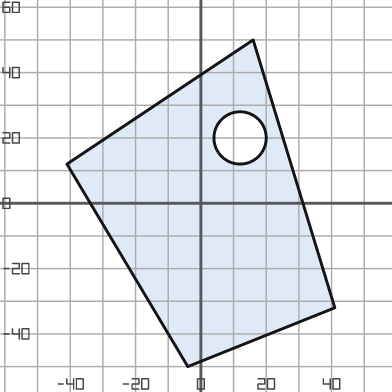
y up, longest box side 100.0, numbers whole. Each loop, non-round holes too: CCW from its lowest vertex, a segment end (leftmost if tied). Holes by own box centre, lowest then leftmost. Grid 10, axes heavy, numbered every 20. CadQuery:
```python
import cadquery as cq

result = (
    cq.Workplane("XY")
    .moveTo(-4.0, -50.0)
    .lineTo(41.0, -32.0)
    .lineTo(16.0, 50.0)
    .lineTo(-41.0, 12.0)
    .close()
    .moveTo(12.0, 20.0)
    .circle(8.0)
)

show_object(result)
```